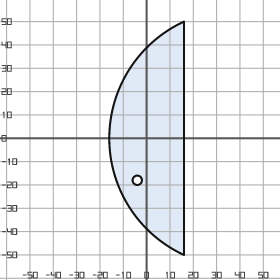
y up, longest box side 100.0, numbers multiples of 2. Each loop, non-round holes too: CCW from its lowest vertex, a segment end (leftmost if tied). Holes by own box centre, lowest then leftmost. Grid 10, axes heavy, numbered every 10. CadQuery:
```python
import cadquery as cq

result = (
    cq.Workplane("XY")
    .moveTo(16.0, -50.0)
    .lineTo(16.0, 50.0)
    .threePointArc((-16.0, 0.0), (16.0, -50.0))
    .close()
    .moveTo(-4.0, -18.0)
    .circle(2.0)
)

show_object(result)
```